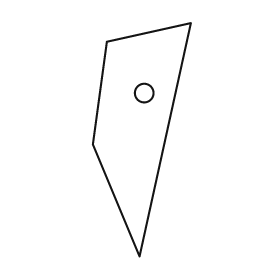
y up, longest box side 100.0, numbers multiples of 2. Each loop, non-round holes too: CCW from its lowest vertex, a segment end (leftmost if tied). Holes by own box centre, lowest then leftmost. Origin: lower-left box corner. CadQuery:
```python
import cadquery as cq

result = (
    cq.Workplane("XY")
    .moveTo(20.0, 0.0)
    .lineTo(42.0, 100.0)
    .lineTo(6.0, 92.0)
    .lineTo(0.0, 48.0)
    .close()
    .moveTo(22.0, 70.0)
    .circle(4.0)
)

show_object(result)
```